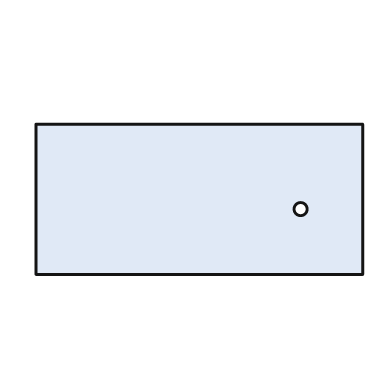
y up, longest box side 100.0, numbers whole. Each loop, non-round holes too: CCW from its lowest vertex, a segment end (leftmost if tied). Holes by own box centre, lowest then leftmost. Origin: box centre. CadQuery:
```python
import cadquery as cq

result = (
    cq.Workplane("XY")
    .moveTo(-50.0, -23.0)
    .lineTo(50.0, -23.0)
    .lineTo(50.0, 23.0)
    .lineTo(-50.0, 23.0)
    .close()
    .moveTo(31.0, -3.0)
    .circle(2.0)
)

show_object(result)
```